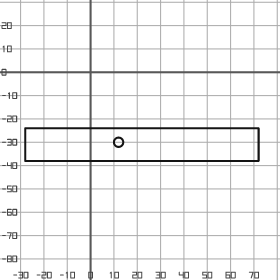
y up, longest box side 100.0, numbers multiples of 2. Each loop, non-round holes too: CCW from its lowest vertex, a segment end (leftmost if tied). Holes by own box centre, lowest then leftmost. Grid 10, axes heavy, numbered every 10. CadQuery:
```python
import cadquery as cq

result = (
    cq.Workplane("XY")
    .moveTo(-28.0, -38.0)
    .lineTo(72.0, -38.0)
    .lineTo(72.0, -24.0)
    .lineTo(-28.0, -24.0)
    .close()
    .moveTo(12.0, -30.0)
    .circle(2.0)
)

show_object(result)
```